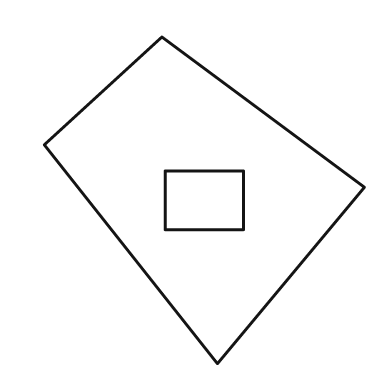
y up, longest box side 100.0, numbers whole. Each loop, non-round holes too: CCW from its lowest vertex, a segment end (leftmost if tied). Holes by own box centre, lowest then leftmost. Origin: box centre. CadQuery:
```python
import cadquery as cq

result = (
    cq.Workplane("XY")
    .moveTo(4.0, -50.0)
    .lineTo(49.0, 4.0)
    .lineTo(-13.0, 50.0)
    .lineTo(-49.0, 17.0)
    .close()
    .moveTo(-12.0, -9.0)
    .lineTo(12.0, -9.0)
    .lineTo(12.0, 9.0)
    .lineTo(-12.0, 9.0)
    .close()
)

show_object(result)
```